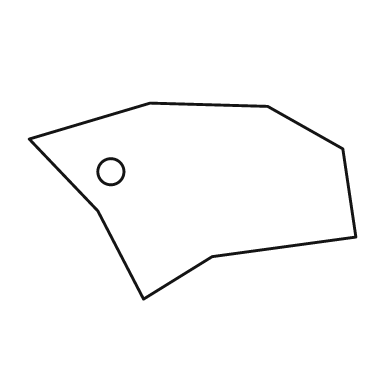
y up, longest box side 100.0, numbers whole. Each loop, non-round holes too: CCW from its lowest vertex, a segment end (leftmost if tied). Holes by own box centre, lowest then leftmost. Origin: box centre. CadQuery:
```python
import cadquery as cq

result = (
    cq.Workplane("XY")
    .moveTo(-15.0, -30.0)
    .lineTo(6.0, -17.0)
    .lineTo(50.0, -11.0)
    .lineTo(46.0, 16.0)
    .lineTo(23.0, 29.0)
    .lineTo(-13.0, 30.0)
    .lineTo(-50.0, 19.0)
    .lineTo(-29.0, -3.0)
    .close()
    .moveTo(-25.0, 9.0)
    .circle(4.0)
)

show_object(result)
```